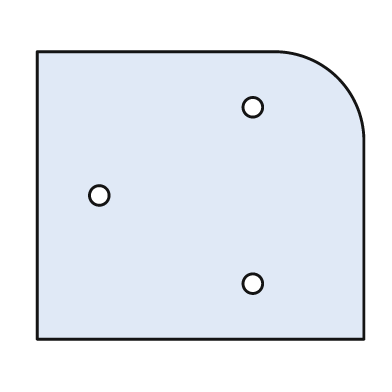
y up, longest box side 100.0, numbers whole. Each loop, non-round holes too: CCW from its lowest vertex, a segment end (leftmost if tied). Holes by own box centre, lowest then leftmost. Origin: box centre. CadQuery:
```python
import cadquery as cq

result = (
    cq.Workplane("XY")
    .moveTo(-50.0, -44.0)
    .lineTo(50.0, -44.0)
    .lineTo(50.0, 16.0)
    .threePointArc((42.0, 36.0), (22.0, 44.0))
    .lineTo(-50.0, 44.0)
    .close()
    .moveTo(16.0, -27.0)
    .circle(3.0)
    .moveTo(-31.0, 0.0)
    .circle(3.0)
    .moveTo(16.0, 27.0)
    .circle(3.0)
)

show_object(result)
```